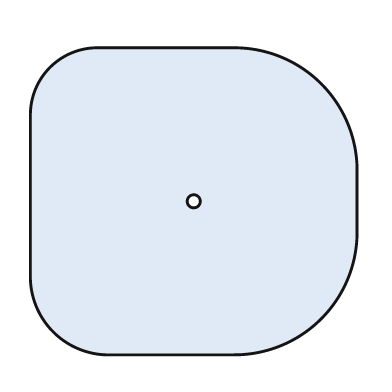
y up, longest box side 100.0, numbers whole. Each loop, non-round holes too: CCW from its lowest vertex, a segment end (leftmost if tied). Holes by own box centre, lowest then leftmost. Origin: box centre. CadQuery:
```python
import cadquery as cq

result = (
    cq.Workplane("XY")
    .moveTo(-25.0, -47.0)
    .lineTo(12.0, -47.0)
    .threePointArc((39.0, -36.0), (50.0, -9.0))
    .lineTo(50.0, 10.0)
    .threePointArc((39.0, 36.0), (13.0, 47.0))
    .lineTo(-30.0, 47.0)
    .threePointArc((-44.0, 41.0), (-50.0, 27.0))
    .lineTo(-50.0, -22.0)
    .threePointArc((-43.0, -40.0), (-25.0, -47.0))
    .close()
    .moveTo(0.0, 0.0)
    .circle(2.0)
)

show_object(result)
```